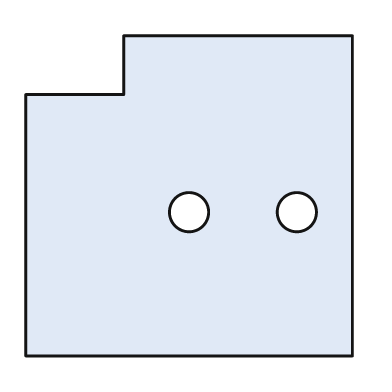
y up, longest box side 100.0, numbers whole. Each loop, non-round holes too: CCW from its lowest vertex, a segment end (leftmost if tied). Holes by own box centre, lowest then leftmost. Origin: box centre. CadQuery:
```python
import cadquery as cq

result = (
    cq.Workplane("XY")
    .moveTo(-50.0, -49.0)
    .lineTo(50.0, -49.0)
    .lineTo(50.0, 49.0)
    .lineTo(-20.0, 49.0)
    .lineTo(-20.0, 31.0)
    .lineTo(-50.0, 31.0)
    .close()
    .moveTo(0.0, -5.0)
    .circle(6.0)
    .moveTo(33.0, -5.0)
    .circle(6.0)
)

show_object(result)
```